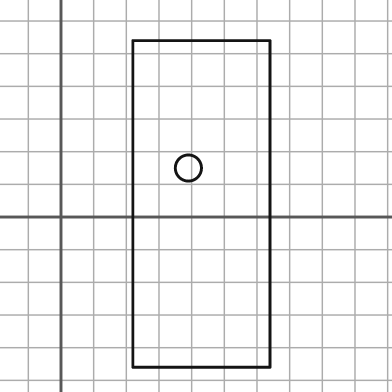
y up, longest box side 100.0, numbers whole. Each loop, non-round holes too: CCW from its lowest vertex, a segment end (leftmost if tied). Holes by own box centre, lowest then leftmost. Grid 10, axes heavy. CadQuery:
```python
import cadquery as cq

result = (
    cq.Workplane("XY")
    .moveTo(22.0, -46.0)
    .lineTo(64.0, -46.0)
    .lineTo(64.0, 54.0)
    .lineTo(22.0, 54.0)
    .close()
    .moveTo(39.0, 15.0)
    .circle(4.0)
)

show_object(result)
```